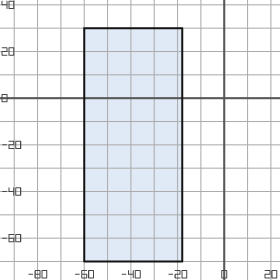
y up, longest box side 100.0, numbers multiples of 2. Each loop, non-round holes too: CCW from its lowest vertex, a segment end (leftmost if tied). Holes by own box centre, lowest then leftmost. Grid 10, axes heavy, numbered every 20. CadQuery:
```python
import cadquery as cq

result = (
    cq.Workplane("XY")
    .moveTo(-60.0, -70.0)
    .lineTo(-18.0, -70.0)
    .lineTo(-18.0, 30.0)
    .lineTo(-60.0, 30.0)
    .close()
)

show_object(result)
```